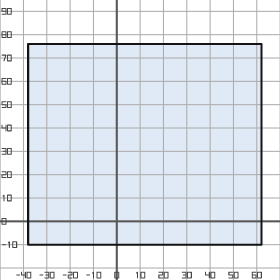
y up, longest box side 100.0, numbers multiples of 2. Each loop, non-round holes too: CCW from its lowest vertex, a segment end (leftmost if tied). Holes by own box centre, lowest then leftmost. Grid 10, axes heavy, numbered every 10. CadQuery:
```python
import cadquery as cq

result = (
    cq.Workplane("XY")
    .moveTo(-38.0, -10.0)
    .lineTo(62.0, -10.0)
    .lineTo(62.0, 76.0)
    .lineTo(-38.0, 76.0)
    .close()
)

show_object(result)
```